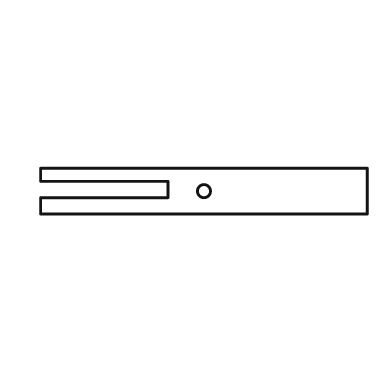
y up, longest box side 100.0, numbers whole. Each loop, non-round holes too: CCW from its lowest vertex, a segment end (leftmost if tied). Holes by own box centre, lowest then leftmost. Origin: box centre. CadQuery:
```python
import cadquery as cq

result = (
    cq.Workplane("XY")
    .moveTo(-50.0, -7.0)
    .lineTo(50.0, -7.0)
    .lineTo(50.0, 7.0)
    .lineTo(-50.0, 7.0)
    .lineTo(-50.0, 3.0)
    .lineTo(-11.0, 3.0)
    .lineTo(-11.0, -2.0)
    .lineTo(-50.0, -2.0)
    .close()
    .moveTo(0.0, 0.0)
    .circle(2.0)
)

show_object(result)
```